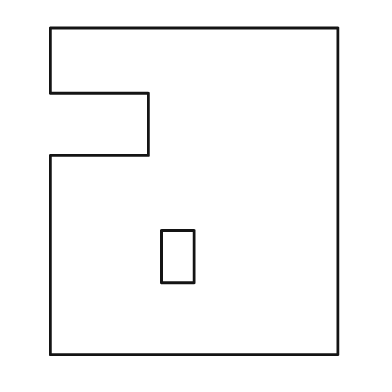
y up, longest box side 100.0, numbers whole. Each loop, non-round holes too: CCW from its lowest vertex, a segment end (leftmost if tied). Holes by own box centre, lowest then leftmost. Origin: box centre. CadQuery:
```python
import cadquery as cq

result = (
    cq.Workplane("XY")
    .moveTo(-44.0, -50.0)
    .lineTo(44.0, -50.0)
    .lineTo(44.0, 50.0)
    .lineTo(-44.0, 50.0)
    .lineTo(-44.0, 30.0)
    .lineTo(-14.0, 30.0)
    .lineTo(-14.0, 11.0)
    .lineTo(-44.0, 11.0)
    .close()
    .moveTo(-10.0, -28.0)
    .lineTo(0.0, -28.0)
    .lineTo(0.0, -12.0)
    .lineTo(-10.0, -12.0)
    .close()
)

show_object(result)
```